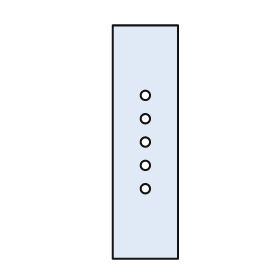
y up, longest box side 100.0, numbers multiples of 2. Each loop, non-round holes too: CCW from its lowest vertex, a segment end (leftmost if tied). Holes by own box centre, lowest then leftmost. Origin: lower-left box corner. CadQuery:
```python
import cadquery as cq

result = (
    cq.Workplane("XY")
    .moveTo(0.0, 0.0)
    .lineTo(28.0, 0.0)
    .lineTo(28.0, 100.0)
    .lineTo(0.0, 100.0)
    .close()
    .moveTo(14.0, 30.0)
    .circle(2.0)
    .moveTo(14.0, 40.0)
    .circle(2.0)
    .moveTo(14.0, 50.0)
    .circle(2.0)
    .moveTo(14.0, 60.0)
    .circle(2.0)
    .moveTo(14.0, 70.0)
    .circle(2.0)
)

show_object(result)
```